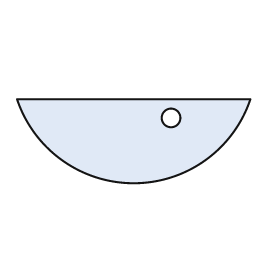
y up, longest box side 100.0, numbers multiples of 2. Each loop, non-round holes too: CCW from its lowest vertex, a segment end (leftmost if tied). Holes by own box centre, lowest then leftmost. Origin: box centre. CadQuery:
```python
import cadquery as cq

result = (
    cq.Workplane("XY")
    .moveTo(-50.0, 18.0)
    .threePointArc((0.0, -18.0), (50.0, 18.0))
    .close()
    .moveTo(16.0, 10.0)
    .circle(4.0)
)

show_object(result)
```